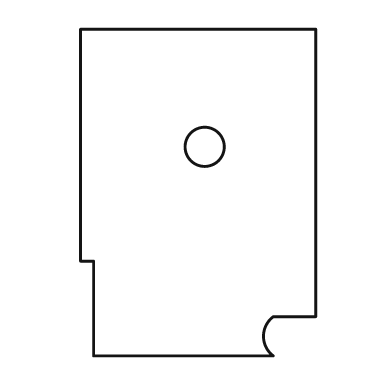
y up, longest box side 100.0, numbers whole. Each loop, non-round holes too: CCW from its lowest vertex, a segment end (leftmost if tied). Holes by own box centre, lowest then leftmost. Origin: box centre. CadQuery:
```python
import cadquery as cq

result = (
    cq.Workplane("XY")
    .moveTo(-32.0, -50.0)
    .lineTo(23.0, -50.0)
    .threePointArc((20.0, -44.0), (23.0, -38.0))
    .lineTo(36.0, -38.0)
    .lineTo(36.0, 50.0)
    .lineTo(-36.0, 50.0)
    .lineTo(-36.0, -21.0)
    .lineTo(-32.0, -21.0)
    .close()
    .moveTo(2.0, 14.0)
    .circle(6.0)
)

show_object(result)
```